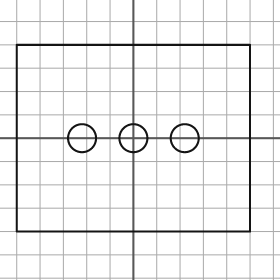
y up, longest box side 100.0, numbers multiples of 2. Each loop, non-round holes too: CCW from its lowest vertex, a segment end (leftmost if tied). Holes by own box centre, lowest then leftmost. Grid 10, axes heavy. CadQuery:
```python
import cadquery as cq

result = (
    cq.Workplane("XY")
    .moveTo(-50.0, -40.0)
    .lineTo(50.0, -40.0)
    .lineTo(50.0, 40.0)
    .lineTo(-50.0, 40.0)
    .close()
    .moveTo(-22.0, 0.0)
    .circle(6.0)
    .moveTo(0.0, 0.0)
    .circle(6.0)
    .moveTo(22.0, 0.0)
    .circle(6.0)
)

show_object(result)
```